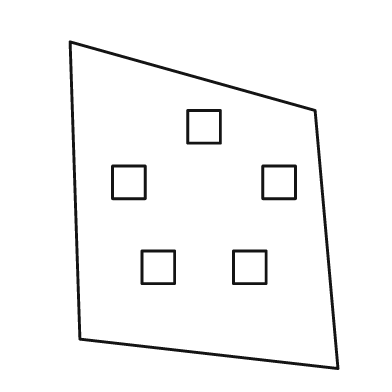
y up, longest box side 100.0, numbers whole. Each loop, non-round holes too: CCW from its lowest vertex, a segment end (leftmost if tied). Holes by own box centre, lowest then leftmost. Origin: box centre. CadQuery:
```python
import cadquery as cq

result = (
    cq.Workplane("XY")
    .moveTo(41.0, -50.0)
    .lineTo(34.0, 29.0)
    .lineTo(-41.0, 50.0)
    .lineTo(-38.0, -41.0)
    .close()
    .moveTo(-19.0, -24.0)
    .lineTo(-9.0, -24.0)
    .lineTo(-9.0, -14.0)
    .lineTo(-19.0, -14.0)
    .close()
    .moveTo(9.0, -24.0)
    .lineTo(19.0, -24.0)
    .lineTo(19.0, -14.0)
    .lineTo(9.0, -14.0)
    .close()
    .moveTo(-28.0, 2.0)
    .lineTo(-18.0, 2.0)
    .lineTo(-18.0, 12.0)
    .lineTo(-28.0, 12.0)
    .close()
    .moveTo(18.0, 2.0)
    .lineTo(28.0, 2.0)
    .lineTo(28.0, 12.0)
    .lineTo(18.0, 12.0)
    .close()
    .moveTo(-5.0, 19.0)
    .lineTo(5.0, 19.0)
    .lineTo(5.0, 29.0)
    .lineTo(-5.0, 29.0)
    .close()
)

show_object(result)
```